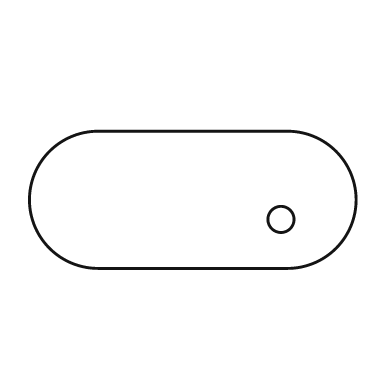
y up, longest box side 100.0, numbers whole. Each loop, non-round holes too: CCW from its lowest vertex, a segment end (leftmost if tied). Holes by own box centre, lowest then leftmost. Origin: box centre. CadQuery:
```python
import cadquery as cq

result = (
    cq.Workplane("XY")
    .moveTo(-29.0, -21.0)
    .lineTo(29.0, -21.0)
    .threePointArc((50.0, 0.0), (29.0, 21.0))
    .lineTo(-29.0, 21.0)
    .threePointArc((-50.0, 0.0), (-29.0, -21.0))
    .close()
    .moveTo(27.0, -6.0)
    .circle(4.0)
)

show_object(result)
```